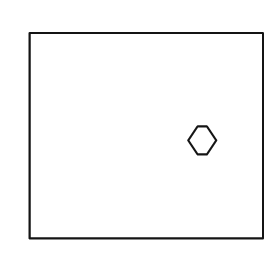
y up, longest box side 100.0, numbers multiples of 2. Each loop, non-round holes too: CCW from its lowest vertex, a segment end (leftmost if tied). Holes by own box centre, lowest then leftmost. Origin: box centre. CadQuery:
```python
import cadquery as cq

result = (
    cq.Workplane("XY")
    .moveTo(-50.0, -44.0)
    .lineTo(50.0, -44.0)
    .lineTo(50.0, 44.0)
    .lineTo(-50.0, 44.0)
    .close()
    .moveTo(22.0, -8.0)
    .lineTo(26.0, -8.0)
    .lineTo(30.0, -2.0)
    .lineTo(26.0, 4.0)
    .lineTo(22.0, 4.0)
    .lineTo(18.0, -2.0)
    .close()
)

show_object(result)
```